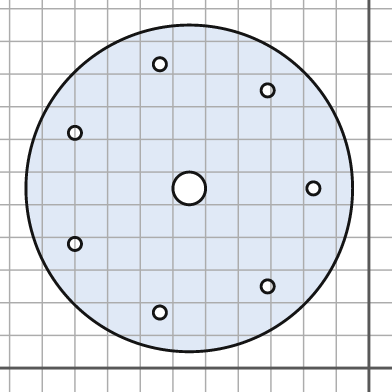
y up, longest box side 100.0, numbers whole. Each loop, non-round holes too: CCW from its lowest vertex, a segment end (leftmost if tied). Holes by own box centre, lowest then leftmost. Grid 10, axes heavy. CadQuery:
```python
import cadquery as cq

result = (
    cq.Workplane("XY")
    .moveTo(-55.0, 55.0)
    .circle(50.0)
    .moveTo(-64.0, 17.0)
    .circle(2.0)
    .moveTo(-31.0, 25.0)
    .circle(2.0)
    .moveTo(-90.0, 38.0)
    .circle(2.0)
    .moveTo(-55.0, 55.0)
    .circle(5.0)
    .moveTo(-17.0, 55.0)
    .circle(2.0)
    .moveTo(-90.0, 72.0)
    .circle(2.0)
    .moveTo(-31.0, 85.0)
    .circle(2.0)
    .moveTo(-64.0, 93.0)
    .circle(2.0)
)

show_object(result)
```